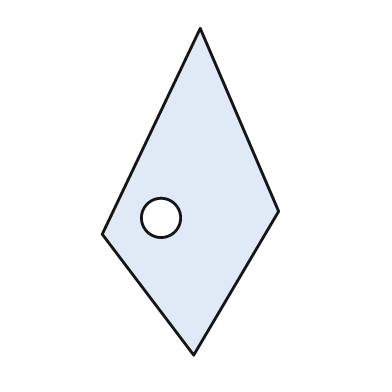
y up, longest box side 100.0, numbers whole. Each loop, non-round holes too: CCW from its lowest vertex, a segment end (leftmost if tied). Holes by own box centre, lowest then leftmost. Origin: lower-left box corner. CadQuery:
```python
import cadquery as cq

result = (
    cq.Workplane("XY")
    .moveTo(28.0, 0.0)
    .lineTo(54.0, 44.0)
    .lineTo(30.0, 100.0)
    .lineTo(0.0, 37.0)
    .close()
    .moveTo(18.0, 42.0)
    .circle(6.0)
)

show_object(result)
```